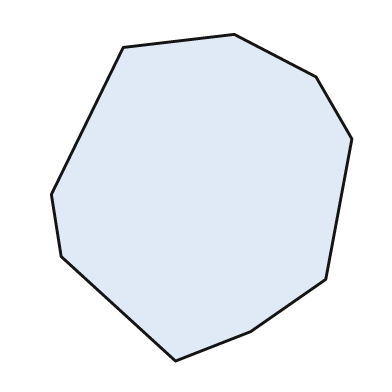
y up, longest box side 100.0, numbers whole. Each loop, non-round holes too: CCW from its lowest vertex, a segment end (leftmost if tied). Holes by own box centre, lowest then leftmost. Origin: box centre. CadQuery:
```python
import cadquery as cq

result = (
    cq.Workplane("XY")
    .moveTo(-8.0, -50.0)
    .lineTo(15.0, -41.0)
    .lineTo(38.0, -25.0)
    .lineTo(46.0, 18.0)
    .lineTo(35.0, 37.0)
    .lineTo(10.0, 50.0)
    .lineTo(-24.0, 46.0)
    .lineTo(-46.0, 1.0)
    .lineTo(-43.0, -18.0)
    .close()
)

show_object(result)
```